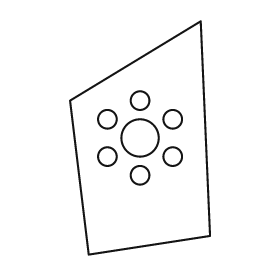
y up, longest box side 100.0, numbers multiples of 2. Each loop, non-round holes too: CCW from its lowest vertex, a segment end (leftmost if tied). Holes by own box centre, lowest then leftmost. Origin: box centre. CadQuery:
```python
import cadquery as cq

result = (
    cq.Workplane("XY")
    .moveTo(-22.0, -50.0)
    .lineTo(30.0, -42.0)
    .lineTo(26.0, 50.0)
    .lineTo(-30.0, 16.0)
    .close()
    .moveTo(0.0, -16.0)
    .circle(4.0)
    .moveTo(-14.0, -8.0)
    .circle(4.0)
    .moveTo(14.0, -8.0)
    .circle(4.0)
    .moveTo(0.0, 0.0)
    .circle(8.0)
    .moveTo(-14.0, 8.0)
    .circle(4.0)
    .moveTo(14.0, 8.0)
    .circle(4.0)
    .moveTo(0.0, 16.0)
    .circle(4.0)
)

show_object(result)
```